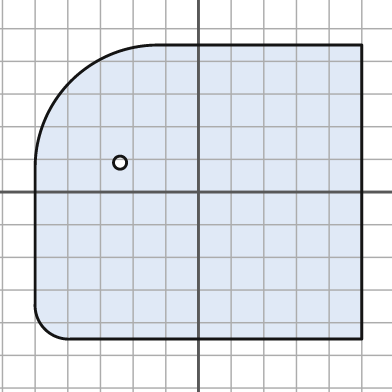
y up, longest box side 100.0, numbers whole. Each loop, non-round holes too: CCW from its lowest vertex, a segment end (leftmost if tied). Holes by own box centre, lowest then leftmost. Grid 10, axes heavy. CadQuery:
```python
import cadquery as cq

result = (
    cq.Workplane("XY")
    .moveTo(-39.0, -45.0)
    .lineTo(50.0, -45.0)
    .lineTo(50.0, 45.0)
    .lineTo(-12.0, 45.0)
    .threePointArc((-39.0, 34.0), (-50.0, 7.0))
    .lineTo(-50.0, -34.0)
    .threePointArc((-47.0, -42.0), (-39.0, -45.0))
    .close()
    .moveTo(-24.0, 9.0)
    .circle(2.0)
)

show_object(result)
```